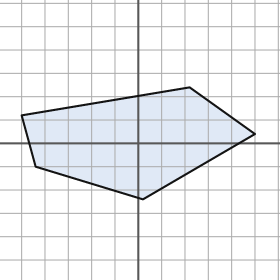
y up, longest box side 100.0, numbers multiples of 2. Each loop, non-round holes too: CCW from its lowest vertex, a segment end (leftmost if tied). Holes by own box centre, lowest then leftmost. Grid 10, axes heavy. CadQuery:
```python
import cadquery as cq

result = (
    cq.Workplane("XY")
    .moveTo(2.0, -24.0)
    .lineTo(50.0, 4.0)
    .lineTo(22.0, 24.0)
    .lineTo(-50.0, 12.0)
    .lineTo(-44.0, -10.0)
    .close()
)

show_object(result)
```